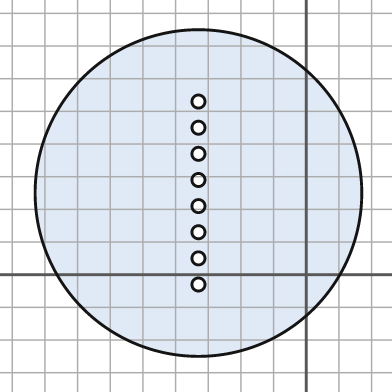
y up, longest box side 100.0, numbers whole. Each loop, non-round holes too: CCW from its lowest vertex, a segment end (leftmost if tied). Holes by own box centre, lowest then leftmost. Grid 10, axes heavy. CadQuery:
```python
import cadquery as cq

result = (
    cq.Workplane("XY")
    .moveTo(-33.0, 25.0)
    .circle(50.0)
    .moveTo(-33.0, -3.0)
    .circle(2.0)
    .moveTo(-33.0, 5.0)
    .circle(2.0)
    .moveTo(-33.0, 13.0)
    .circle(2.0)
    .moveTo(-33.0, 21.0)
    .circle(2.0)
    .moveTo(-33.0, 29.0)
    .circle(2.0)
    .moveTo(-33.0, 37.0)
    .circle(2.0)
    .moveTo(-33.0, 45.0)
    .circle(2.0)
    .moveTo(-33.0, 53.0)
    .circle(2.0)
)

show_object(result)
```